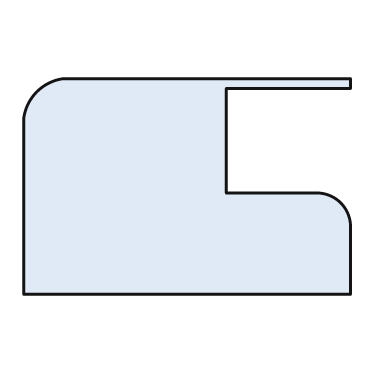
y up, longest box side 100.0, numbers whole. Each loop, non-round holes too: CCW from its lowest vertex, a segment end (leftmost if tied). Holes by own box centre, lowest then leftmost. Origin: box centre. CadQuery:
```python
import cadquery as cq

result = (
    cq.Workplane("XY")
    .moveTo(-50.0, -33.0)
    .lineTo(50.0, -33.0)
    .lineTo(50.0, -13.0)
    .threePointArc((47.0, -5.0), (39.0, -2.0))
    .lineTo(12.0, -2.0)
    .lineTo(12.0, 30.0)
    .lineTo(50.0, 30.0)
    .lineTo(50.0, 33.0)
    .lineTo(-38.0, 33.0)
    .threePointArc((-46.0, 29.0), (-50.0, 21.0))
    .close()
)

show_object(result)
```